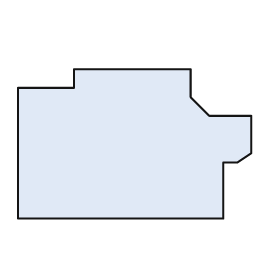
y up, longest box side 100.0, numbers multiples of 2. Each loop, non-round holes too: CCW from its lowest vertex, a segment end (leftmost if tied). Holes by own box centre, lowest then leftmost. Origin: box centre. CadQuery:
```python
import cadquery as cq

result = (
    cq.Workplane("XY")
    .moveTo(-50.0, -32.0)
    .lineTo(38.0, -32.0)
    .lineTo(38.0, -8.0)
    .lineTo(44.0, -8.0)
    .lineTo(50.0, -4.0)
    .lineTo(50.0, 12.0)
    .lineTo(32.0, 12.0)
    .lineTo(24.0, 20.0)
    .lineTo(24.0, 32.0)
    .lineTo(-26.0, 32.0)
    .lineTo(-26.0, 24.0)
    .lineTo(-50.0, 24.0)
    .close()
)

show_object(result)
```